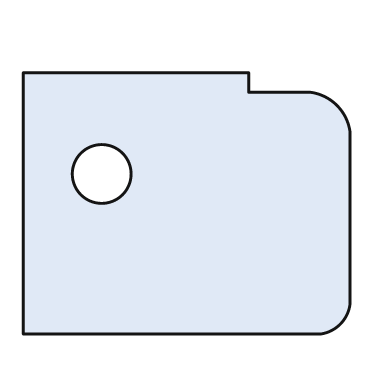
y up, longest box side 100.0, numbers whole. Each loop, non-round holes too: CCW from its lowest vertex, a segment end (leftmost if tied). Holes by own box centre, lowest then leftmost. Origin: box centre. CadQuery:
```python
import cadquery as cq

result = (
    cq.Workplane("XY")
    .moveTo(-50.0, -40.0)
    .lineTo(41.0, -40.0)
    .threePointArc((47.0, -37.0), (50.0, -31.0))
    .lineTo(50.0, 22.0)
    .threePointArc((46.0, 30.0), (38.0, 34.0))
    .lineTo(19.0, 34.0)
    .lineTo(19.0, 40.0)
    .lineTo(-50.0, 40.0)
    .close()
    .moveTo(-26.0, 9.0)
    .circle(9.0)
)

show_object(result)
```